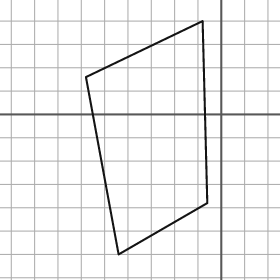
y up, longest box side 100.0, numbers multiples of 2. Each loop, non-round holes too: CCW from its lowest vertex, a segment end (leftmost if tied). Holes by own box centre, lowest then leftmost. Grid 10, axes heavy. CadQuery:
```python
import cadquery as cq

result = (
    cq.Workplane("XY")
    .moveTo(-44.0, -60.0)
    .lineTo(-6.0, -38.0)
    .lineTo(-8.0, 40.0)
    .lineTo(-58.0, 16.0)
    .close()
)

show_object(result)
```